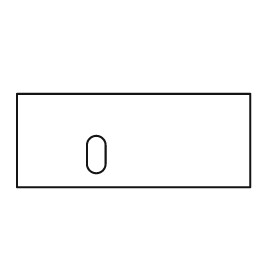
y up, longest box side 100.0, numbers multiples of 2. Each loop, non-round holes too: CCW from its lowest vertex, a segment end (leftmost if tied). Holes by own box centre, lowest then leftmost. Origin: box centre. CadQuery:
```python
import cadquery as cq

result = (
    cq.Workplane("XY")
    .moveTo(-50.0, -20.0)
    .lineTo(50.0, -20.0)
    .lineTo(50.0, 20.0)
    .lineTo(-50.0, 20.0)
    .close()
    .moveTo(-20.0, -10.0)
    .threePointArc((-16.0, -14.0), (-12.0, -10.0))
    .lineTo(-12.0, -2.0)
    .threePointArc((-16.0, 2.0), (-20.0, -2.0))
    .close()
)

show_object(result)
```